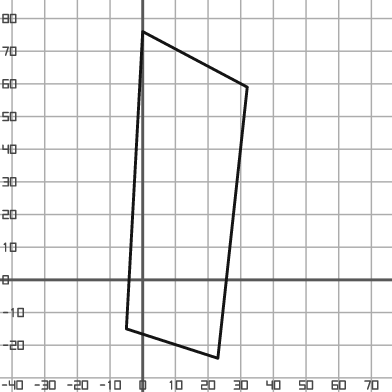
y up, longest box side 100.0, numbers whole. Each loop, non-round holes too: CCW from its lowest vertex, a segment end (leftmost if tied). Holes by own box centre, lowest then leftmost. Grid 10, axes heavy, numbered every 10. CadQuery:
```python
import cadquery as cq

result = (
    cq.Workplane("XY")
    .moveTo(23.0, -24.0)
    .lineTo(32.0, 59.0)
    .lineTo(0.0, 76.0)
    .lineTo(-5.0, -15.0)
    .close()
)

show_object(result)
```